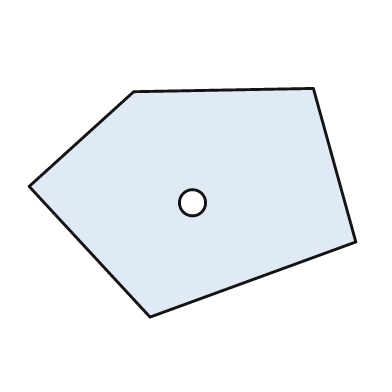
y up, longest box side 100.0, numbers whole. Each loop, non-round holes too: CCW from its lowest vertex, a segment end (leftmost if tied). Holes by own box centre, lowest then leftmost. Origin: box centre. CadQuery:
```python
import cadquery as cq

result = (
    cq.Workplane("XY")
    .moveTo(-13.0, -35.0)
    .lineTo(50.0, -12.0)
    .lineTo(37.0, 35.0)
    .lineTo(-18.0, 34.0)
    .lineTo(-50.0, 5.0)
    .close()
    .moveTo(0.0, 0.0)
    .circle(4.0)
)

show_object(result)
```